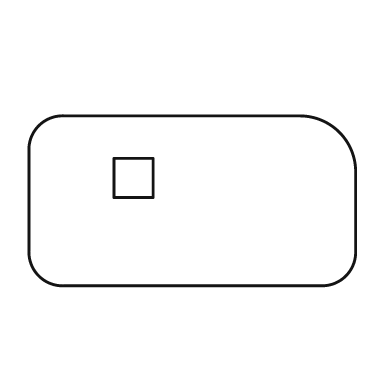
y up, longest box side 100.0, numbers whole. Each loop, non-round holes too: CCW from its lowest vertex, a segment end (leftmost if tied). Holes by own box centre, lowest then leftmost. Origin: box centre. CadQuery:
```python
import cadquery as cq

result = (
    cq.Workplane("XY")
    .moveTo(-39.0, -26.0)
    .lineTo(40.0, -26.0)
    .threePointArc((47.0, -23.0), (50.0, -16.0))
    .lineTo(50.0, 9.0)
    .threePointArc((45.0, 21.0), (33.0, 26.0))
    .lineTo(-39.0, 26.0)
    .threePointArc((-47.0, 23.0), (-50.0, 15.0))
    .lineTo(-50.0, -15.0)
    .threePointArc((-47.0, -23.0), (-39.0, -26.0))
    .close()
    .moveTo(-24.0, 1.0)
    .lineTo(-12.0, 1.0)
    .lineTo(-12.0, 13.0)
    .lineTo(-24.0, 13.0)
    .close()
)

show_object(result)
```